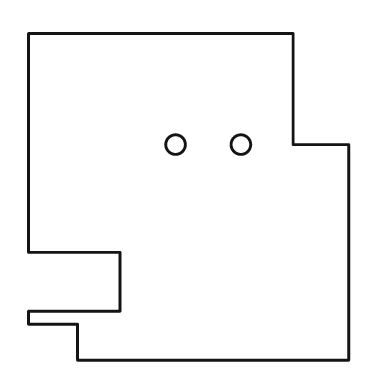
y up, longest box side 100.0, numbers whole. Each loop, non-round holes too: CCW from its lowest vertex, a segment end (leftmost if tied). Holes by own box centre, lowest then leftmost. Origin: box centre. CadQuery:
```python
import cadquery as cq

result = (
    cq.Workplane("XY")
    .moveTo(-34.0, -50.0)
    .lineTo(49.0, -50.0)
    .lineTo(49.0, 16.0)
    .lineTo(32.0, 16.0)
    .lineTo(32.0, 50.0)
    .lineTo(-49.0, 50.0)
    .lineTo(-49.0, -17.0)
    .lineTo(-21.0, -17.0)
    .lineTo(-21.0, -35.0)
    .lineTo(-49.0, -35.0)
    .lineTo(-49.0, -39.0)
    .lineTo(-34.0, -39.0)
    .close()
    .moveTo(-4.0, 16.0)
    .circle(3.0)
    .moveTo(16.0, 16.0)
    .circle(3.0)
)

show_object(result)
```